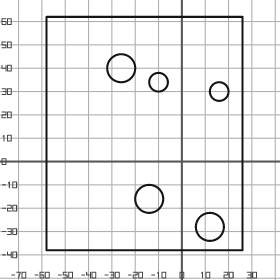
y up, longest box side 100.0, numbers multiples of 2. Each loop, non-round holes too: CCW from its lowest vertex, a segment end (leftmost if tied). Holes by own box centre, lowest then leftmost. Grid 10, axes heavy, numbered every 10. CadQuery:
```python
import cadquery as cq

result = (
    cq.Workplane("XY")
    .moveTo(-58.0, -38.0)
    .lineTo(26.0, -38.0)
    .lineTo(26.0, 62.0)
    .lineTo(-58.0, 62.0)
    .close()
    .moveTo(12.0, -28.0)
    .circle(6.0)
    .moveTo(-14.0, -16.0)
    .circle(6.0)
    .moveTo(16.0, 30.0)
    .circle(4.0)
    .moveTo(-10.0, 34.0)
    .circle(4.0)
    .moveTo(-26.0, 40.0)
    .circle(6.0)
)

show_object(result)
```